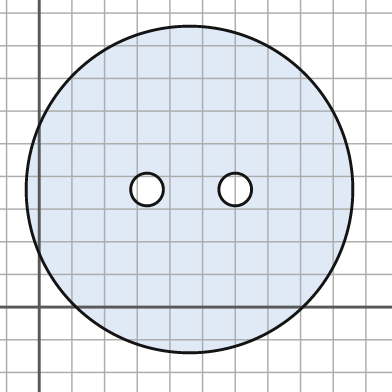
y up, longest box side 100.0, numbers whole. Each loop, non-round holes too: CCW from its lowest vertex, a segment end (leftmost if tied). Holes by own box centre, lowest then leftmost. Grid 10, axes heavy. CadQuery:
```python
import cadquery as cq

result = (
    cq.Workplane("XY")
    .moveTo(46.0, 36.0)
    .circle(50.0)
    .moveTo(33.0, 36.0)
    .circle(5.0)
    .moveTo(60.0, 36.0)
    .circle(5.0)
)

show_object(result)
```